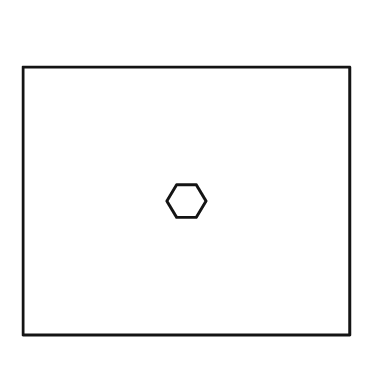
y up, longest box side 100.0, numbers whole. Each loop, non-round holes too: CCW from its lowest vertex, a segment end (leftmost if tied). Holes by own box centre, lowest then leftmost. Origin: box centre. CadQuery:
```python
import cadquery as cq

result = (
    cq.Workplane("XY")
    .moveTo(-50.0, -41.0)
    .lineTo(50.0, -41.0)
    .lineTo(50.0, 41.0)
    .lineTo(-50.0, 41.0)
    .close()
    .moveTo(-3.0, -5.0)
    .lineTo(3.0, -5.0)
    .lineTo(6.0, 0.0)
    .lineTo(3.0, 5.0)
    .lineTo(-3.0, 5.0)
    .lineTo(-6.0, 0.0)
    .close()
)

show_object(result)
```